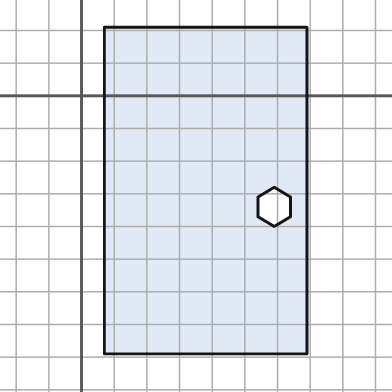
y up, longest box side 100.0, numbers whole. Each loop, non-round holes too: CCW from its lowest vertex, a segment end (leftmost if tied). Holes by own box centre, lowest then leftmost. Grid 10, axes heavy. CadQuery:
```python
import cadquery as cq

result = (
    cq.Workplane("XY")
    .moveTo(7.0, -79.0)
    .lineTo(69.0, -79.0)
    .lineTo(69.0, 21.0)
    .lineTo(7.0, 21.0)
    .close()
    .moveTo(59.0, -40.0)
    .lineTo(64.0, -37.0)
    .lineTo(64.0, -31.0)
    .lineTo(59.0, -28.0)
    .lineTo(54.0, -31.0)
    .lineTo(54.0, -37.0)
    .close()
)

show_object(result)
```